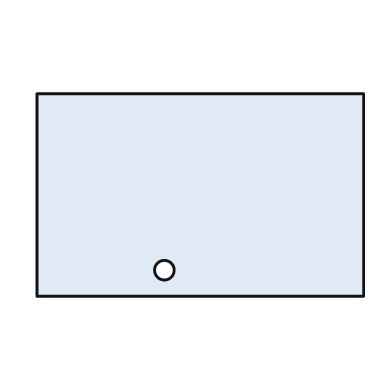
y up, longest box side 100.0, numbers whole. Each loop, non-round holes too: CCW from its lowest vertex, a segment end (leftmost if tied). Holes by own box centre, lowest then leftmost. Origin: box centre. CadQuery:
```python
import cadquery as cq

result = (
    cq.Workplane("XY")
    .moveTo(-50.0, -31.0)
    .lineTo(50.0, -31.0)
    .lineTo(50.0, 31.0)
    .lineTo(-50.0, 31.0)
    .close()
    .moveTo(-11.0, -23.0)
    .circle(3.0)
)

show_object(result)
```